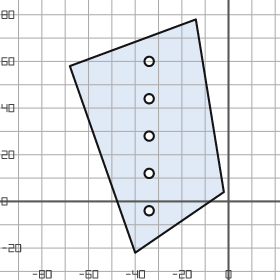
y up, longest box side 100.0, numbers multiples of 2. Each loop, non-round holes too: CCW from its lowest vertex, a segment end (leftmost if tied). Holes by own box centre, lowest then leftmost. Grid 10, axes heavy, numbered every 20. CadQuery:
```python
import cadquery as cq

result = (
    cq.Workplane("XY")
    .moveTo(-40.0, -22.0)
    .lineTo(-2.0, 4.0)
    .lineTo(-14.0, 78.0)
    .lineTo(-68.0, 58.0)
    .close()
    .moveTo(-34.0, -4.0)
    .circle(2.0)
    .moveTo(-34.0, 12.0)
    .circle(2.0)
    .moveTo(-34.0, 28.0)
    .circle(2.0)
    .moveTo(-34.0, 44.0)
    .circle(2.0)
    .moveTo(-34.0, 60.0)
    .circle(2.0)
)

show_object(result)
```